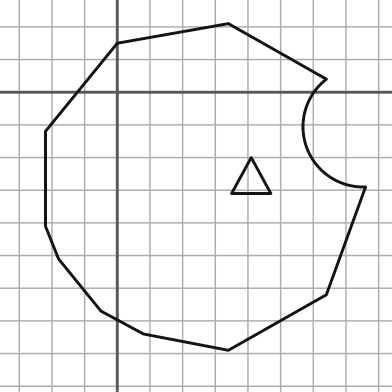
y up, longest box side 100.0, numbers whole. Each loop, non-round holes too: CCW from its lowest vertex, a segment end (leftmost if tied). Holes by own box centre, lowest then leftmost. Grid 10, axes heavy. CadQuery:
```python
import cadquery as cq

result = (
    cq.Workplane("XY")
    .moveTo(34.0, -79.0)
    .lineTo(64.0, -62.0)
    .lineTo(76.0, -29.0)
    .threePointArc((58.0, -17.0), (64.0, 4.0))
    .lineTo(34.0, 21.0)
    .lineTo(0.0, 15.0)
    .lineTo(-22.0, -12.0)
    .lineTo(-22.0, -41.0)
    .lineTo(-18.0, -51.0)
    .lineTo(-5.0, -67.0)
    .lineTo(8.0, -74.0)
    .close()
    .moveTo(35.0, -31.0)
    .lineTo(47.0, -31.0)
    .lineTo(41.0, -20.0)
    .close()
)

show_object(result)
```